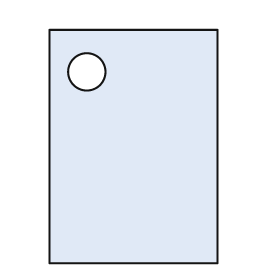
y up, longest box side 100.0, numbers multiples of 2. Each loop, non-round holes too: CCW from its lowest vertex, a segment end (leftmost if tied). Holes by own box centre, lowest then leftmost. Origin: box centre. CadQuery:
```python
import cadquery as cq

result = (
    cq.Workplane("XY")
    .moveTo(-36.0, -50.0)
    .lineTo(36.0, -50.0)
    .lineTo(36.0, 50.0)
    .lineTo(-36.0, 50.0)
    .close()
    .moveTo(-20.0, 32.0)
    .circle(8.0)
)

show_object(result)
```